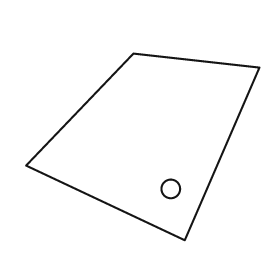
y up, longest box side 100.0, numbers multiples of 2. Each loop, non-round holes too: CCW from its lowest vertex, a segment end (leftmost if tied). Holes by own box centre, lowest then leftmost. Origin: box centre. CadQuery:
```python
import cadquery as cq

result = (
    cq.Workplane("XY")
    .moveTo(18.0, -40.0)
    .lineTo(50.0, 34.0)
    .lineTo(-4.0, 40.0)
    .lineTo(-50.0, -8.0)
    .close()
    .moveTo(12.0, -18.0)
    .circle(4.0)
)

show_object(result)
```